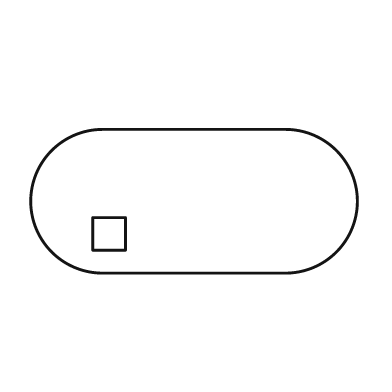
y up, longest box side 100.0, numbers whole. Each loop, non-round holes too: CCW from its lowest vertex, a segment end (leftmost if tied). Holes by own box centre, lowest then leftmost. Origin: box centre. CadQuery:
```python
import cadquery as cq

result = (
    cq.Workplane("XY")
    .moveTo(-28.0, -22.0)
    .lineTo(28.0, -22.0)
    .threePointArc((50.0, 0.0), (28.0, 22.0))
    .lineTo(-28.0, 22.0)
    .threePointArc((-50.0, 0.0), (-28.0, -22.0))
    .close()
    .moveTo(-31.0, -15.0)
    .lineTo(-21.0, -15.0)
    .lineTo(-21.0, -5.0)
    .lineTo(-31.0, -5.0)
    .close()
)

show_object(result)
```